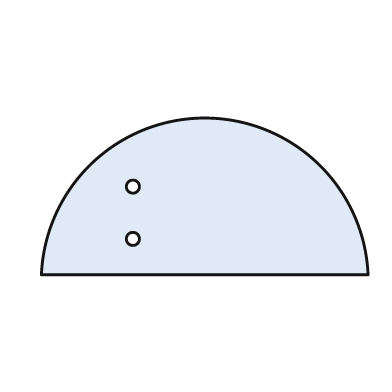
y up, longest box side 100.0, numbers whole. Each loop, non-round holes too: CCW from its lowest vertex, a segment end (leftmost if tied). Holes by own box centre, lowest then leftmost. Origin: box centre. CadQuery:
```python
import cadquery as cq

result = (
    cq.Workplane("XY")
    .moveTo(-50.0, -24.0)
    .lineTo(50.0, -24.0)
    .threePointArc((0.0, 24.0), (-50.0, -24.0))
    .close()
    .moveTo(-22.0, -13.0)
    .circle(2.0)
    .moveTo(-22.0, 3.0)
    .circle(2.0)
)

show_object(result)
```